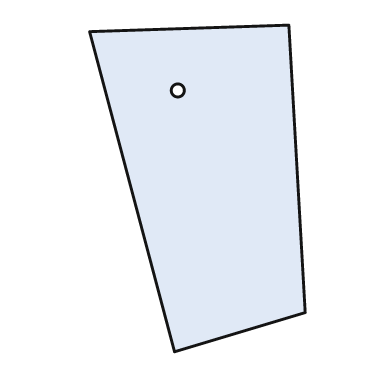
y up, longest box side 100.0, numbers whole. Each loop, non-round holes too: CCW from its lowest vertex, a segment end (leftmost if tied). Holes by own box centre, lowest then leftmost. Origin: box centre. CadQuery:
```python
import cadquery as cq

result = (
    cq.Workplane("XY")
    .moveTo(-7.0, -50.0)
    .lineTo(33.0, -38.0)
    .lineTo(28.0, 50.0)
    .lineTo(-33.0, 48.0)
    .close()
    .moveTo(-6.0, 30.0)
    .circle(2.0)
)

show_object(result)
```